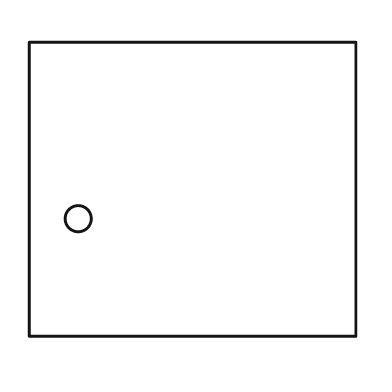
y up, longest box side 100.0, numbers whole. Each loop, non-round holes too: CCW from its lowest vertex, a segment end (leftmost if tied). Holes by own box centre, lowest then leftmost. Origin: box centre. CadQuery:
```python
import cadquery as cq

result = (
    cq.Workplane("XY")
    .moveTo(-50.0, -45.0)
    .lineTo(50.0, -45.0)
    .lineTo(50.0, 45.0)
    .lineTo(-50.0, 45.0)
    .close()
    .moveTo(-35.0, -9.0)
    .circle(4.0)
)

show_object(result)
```